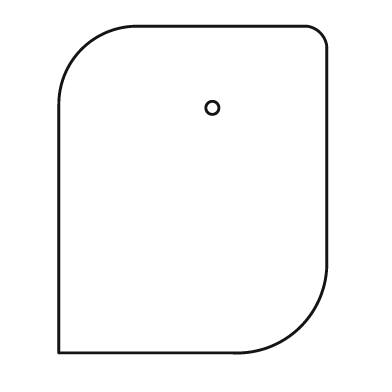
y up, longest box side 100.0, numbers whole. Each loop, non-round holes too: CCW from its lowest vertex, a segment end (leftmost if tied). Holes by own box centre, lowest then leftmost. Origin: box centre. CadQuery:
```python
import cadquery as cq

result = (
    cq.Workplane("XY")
    .moveTo(-41.0, -50.0)
    .lineTo(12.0, -50.0)
    .threePointArc((33.0, -42.0), (41.0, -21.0))
    .lineTo(41.0, 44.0)
    .threePointArc((39.0, 48.0), (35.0, 50.0))
    .lineTo(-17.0, 50.0)
    .threePointArc((-34.0, 43.0), (-41.0, 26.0))
    .close()
    .moveTo(6.0, 25.0)
    .circle(2.0)
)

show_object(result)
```